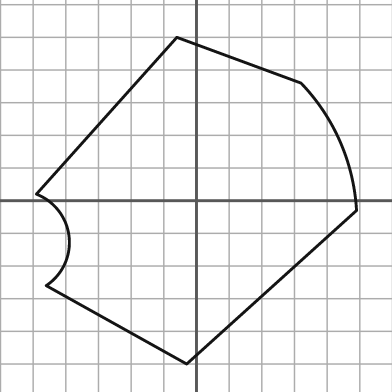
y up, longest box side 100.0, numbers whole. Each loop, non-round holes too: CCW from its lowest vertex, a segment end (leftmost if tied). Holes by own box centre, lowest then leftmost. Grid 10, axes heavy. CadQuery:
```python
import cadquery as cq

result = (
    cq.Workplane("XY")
    .moveTo(-3.0, -50.0)
    .lineTo(49.0, -3.0)
    .threePointArc((44.0, 18.0), (32.0, 36.0))
    .lineTo(-6.0, 50.0)
    .lineTo(-49.0, 2.0)
    .threePointArc((-39.0, -11.0), (-46.0, -26.0))
    .close()
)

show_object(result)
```